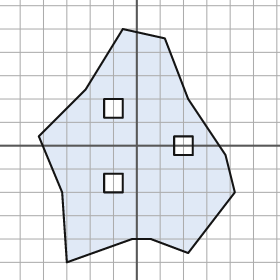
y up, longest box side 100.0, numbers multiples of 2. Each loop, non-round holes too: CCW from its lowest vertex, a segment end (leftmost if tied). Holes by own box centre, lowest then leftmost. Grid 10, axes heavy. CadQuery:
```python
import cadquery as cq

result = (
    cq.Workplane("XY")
    .moveTo(-30.0, -50.0)
    .lineTo(-2.0, -40.0)
    .lineTo(6.0, -40.0)
    .lineTo(22.0, -46.0)
    .lineTo(42.0, -20.0)
    .lineTo(38.0, -4.0)
    .lineTo(22.0, 20.0)
    .lineTo(12.0, 46.0)
    .lineTo(-6.0, 50.0)
    .lineTo(-22.0, 24.0)
    .lineTo(-42.0, 4.0)
    .lineTo(-32.0, -20.0)
    .close()
    .moveTo(-14.0, -20.0)
    .lineTo(-6.0, -20.0)
    .lineTo(-6.0, -12.0)
    .lineTo(-14.0, -12.0)
    .close()
    .moveTo(16.0, -4.0)
    .lineTo(24.0, -4.0)
    .lineTo(24.0, 4.0)
    .lineTo(16.0, 4.0)
    .close()
    .moveTo(-14.0, 12.0)
    .lineTo(-6.0, 12.0)
    .lineTo(-6.0, 20.0)
    .lineTo(-14.0, 20.0)
    .close()
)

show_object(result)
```